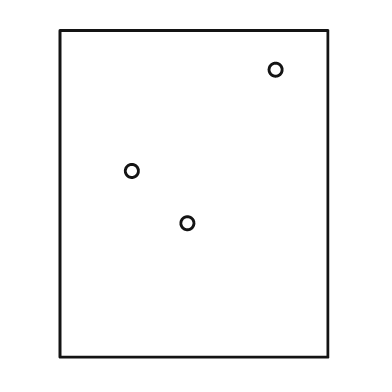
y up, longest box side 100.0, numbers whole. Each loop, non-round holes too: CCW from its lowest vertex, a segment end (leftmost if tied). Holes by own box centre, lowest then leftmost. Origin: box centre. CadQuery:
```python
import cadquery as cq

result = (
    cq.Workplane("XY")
    .moveTo(-41.0, -50.0)
    .lineTo(41.0, -50.0)
    .lineTo(41.0, 50.0)
    .lineTo(-41.0, 50.0)
    .close()
    .moveTo(-2.0, -9.0)
    .circle(2.0)
    .moveTo(-19.0, 7.0)
    .circle(2.0)
    .moveTo(25.0, 38.0)
    .circle(2.0)
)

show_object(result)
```